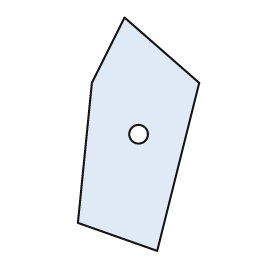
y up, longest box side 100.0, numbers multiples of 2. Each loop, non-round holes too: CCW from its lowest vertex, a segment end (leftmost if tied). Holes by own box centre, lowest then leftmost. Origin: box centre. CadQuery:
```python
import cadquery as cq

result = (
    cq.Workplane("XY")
    .moveTo(8.0, -50.0)
    .lineTo(26.0, 22.0)
    .lineTo(-6.0, 50.0)
    .lineTo(-20.0, 22.0)
    .lineTo(-26.0, -38.0)
    .close()
    .moveTo(0.0, 0.0)
    .circle(4.0)
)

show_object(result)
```